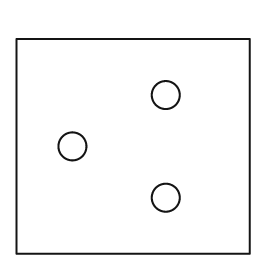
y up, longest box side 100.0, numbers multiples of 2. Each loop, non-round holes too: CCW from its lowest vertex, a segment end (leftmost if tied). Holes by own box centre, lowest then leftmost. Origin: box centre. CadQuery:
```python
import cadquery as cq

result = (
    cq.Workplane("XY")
    .moveTo(-50.0, -46.0)
    .lineTo(50.0, -46.0)
    .lineTo(50.0, 46.0)
    .lineTo(-50.0, 46.0)
    .close()
    .moveTo(14.0, -22.0)
    .circle(6.0)
    .moveTo(-26.0, 0.0)
    .circle(6.0)
    .moveTo(14.0, 22.0)
    .circle(6.0)
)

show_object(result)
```